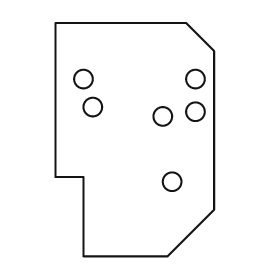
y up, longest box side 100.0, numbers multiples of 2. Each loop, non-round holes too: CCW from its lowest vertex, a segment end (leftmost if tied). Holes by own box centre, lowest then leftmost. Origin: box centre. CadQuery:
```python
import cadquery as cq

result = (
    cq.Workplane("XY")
    .moveTo(-22.0, -50.0)
    .lineTo(14.0, -50.0)
    .lineTo(34.0, -30.0)
    .lineTo(34.0, 38.0)
    .lineTo(22.0, 50.0)
    .lineTo(-34.0, 50.0)
    .lineTo(-34.0, -16.0)
    .lineTo(-22.0, -16.0)
    .close()
    .moveTo(16.0, -18.0)
    .circle(4.0)
    .moveTo(12.0, 10.0)
    .circle(4.0)
    .moveTo(26.0, 12.0)
    .circle(4.0)
    .moveTo(-18.0, 14.0)
    .circle(4.0)
    .moveTo(-22.0, 26.0)
    .circle(4.0)
    .moveTo(26.0, 26.0)
    .circle(4.0)
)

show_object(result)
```